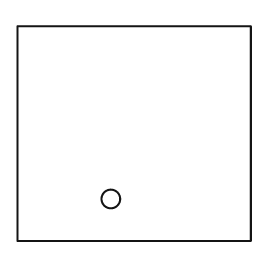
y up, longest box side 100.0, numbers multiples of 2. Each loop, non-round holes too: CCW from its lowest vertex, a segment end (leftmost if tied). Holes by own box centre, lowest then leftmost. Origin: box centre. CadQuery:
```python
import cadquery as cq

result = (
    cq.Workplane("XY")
    .moveTo(-50.0, -46.0)
    .lineTo(50.0, -46.0)
    .lineTo(50.0, 46.0)
    .lineTo(-50.0, 46.0)
    .close()
    .moveTo(-10.0, -28.0)
    .circle(4.0)
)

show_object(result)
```